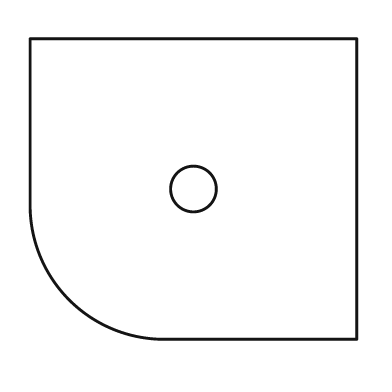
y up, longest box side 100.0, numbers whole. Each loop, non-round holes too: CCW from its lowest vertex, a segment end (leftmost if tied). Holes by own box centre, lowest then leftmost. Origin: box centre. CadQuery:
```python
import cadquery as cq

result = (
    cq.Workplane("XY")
    .moveTo(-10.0, -46.0)
    .lineTo(50.0, -46.0)
    .lineTo(50.0, 46.0)
    .lineTo(-50.0, 46.0)
    .lineTo(-50.0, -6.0)
    .threePointArc((-38.0, -34.0), (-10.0, -46.0))
    .close()
    .moveTo(0.0, 0.0)
    .circle(7.0)
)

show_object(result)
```